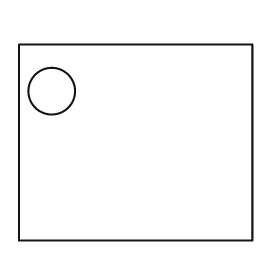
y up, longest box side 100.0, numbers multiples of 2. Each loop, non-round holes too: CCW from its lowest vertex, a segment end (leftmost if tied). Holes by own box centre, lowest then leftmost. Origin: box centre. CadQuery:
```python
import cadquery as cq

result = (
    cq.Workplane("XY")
    .moveTo(-50.0, -42.0)
    .lineTo(50.0, -42.0)
    .lineTo(50.0, 42.0)
    .lineTo(-50.0, 42.0)
    .close()
    .moveTo(-36.0, 22.0)
    .circle(10.0)
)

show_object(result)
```